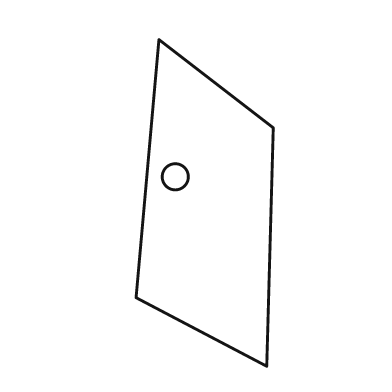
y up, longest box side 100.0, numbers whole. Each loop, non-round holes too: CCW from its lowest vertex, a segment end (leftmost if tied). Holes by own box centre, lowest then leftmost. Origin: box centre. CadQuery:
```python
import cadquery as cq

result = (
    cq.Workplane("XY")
    .moveTo(19.0, -50.0)
    .lineTo(21.0, 23.0)
    .lineTo(-14.0, 50.0)
    .lineTo(-21.0, -29.0)
    .close()
    .moveTo(-9.0, 8.0)
    .circle(4.0)
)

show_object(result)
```